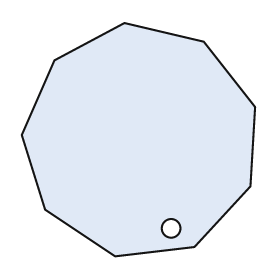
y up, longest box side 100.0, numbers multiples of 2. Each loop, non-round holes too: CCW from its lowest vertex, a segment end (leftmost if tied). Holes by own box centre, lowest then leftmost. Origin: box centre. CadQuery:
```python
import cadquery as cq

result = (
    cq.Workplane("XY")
    .moveTo(-10.0, -50.0)
    .lineTo(24.0, -46.0)
    .lineTo(48.0, -20.0)
    .lineTo(50.0, 14.0)
    .lineTo(28.0, 42.0)
    .lineTo(-6.0, 50.0)
    .lineTo(-36.0, 34.0)
    .lineTo(-50.0, 2.0)
    .lineTo(-40.0, -30.0)
    .close()
    .moveTo(14.0, -38.0)
    .circle(4.0)
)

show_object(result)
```